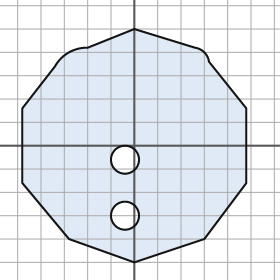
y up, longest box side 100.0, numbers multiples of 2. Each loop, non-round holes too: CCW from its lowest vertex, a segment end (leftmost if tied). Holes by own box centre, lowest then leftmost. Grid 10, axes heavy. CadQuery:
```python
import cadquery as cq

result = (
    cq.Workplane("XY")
    .moveTo(0.0, -50.0)
    .lineTo(30.0, -40.0)
    .lineTo(48.0, -16.0)
    .lineTo(48.0, 16.0)
    .lineTo(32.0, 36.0)
    .threePointArc((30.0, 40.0), (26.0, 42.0))
    .lineTo(0.0, 50.0)
    .lineTo(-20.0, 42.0)
    .threePointArc((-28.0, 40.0), (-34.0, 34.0))
    .lineTo(-48.0, 16.0)
    .lineTo(-48.0, -16.0)
    .lineTo(-28.0, -40.0)
    .close()
    .moveTo(-4.0, -30.0)
    .circle(6.0)
    .moveTo(-4.0, -6.0)
    .circle(6.0)
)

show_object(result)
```